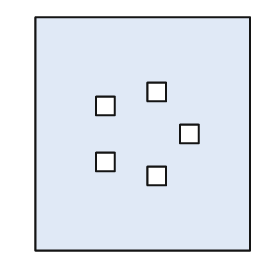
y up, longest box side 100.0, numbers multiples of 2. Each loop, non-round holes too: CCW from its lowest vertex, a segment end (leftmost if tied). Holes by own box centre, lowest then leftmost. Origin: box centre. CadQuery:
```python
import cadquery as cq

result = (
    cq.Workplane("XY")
    .moveTo(-46.0, -50.0)
    .lineTo(46.0, -50.0)
    .lineTo(46.0, 50.0)
    .lineTo(-46.0, 50.0)
    .close()
    .moveTo(2.0, -22.0)
    .lineTo(10.0, -22.0)
    .lineTo(10.0, -14.0)
    .lineTo(2.0, -14.0)
    .close()
    .moveTo(-20.0, -16.0)
    .lineTo(-12.0, -16.0)
    .lineTo(-12.0, -8.0)
    .lineTo(-20.0, -8.0)
    .close()
    .moveTo(16.0, -4.0)
    .lineTo(24.0, -4.0)
    .lineTo(24.0, 4.0)
    .lineTo(16.0, 4.0)
    .close()
    .moveTo(-20.0, 8.0)
    .lineTo(-12.0, 8.0)
    .lineTo(-12.0, 16.0)
    .lineTo(-20.0, 16.0)
    .close()
    .moveTo(2.0, 14.0)
    .lineTo(10.0, 14.0)
    .lineTo(10.0, 22.0)
    .lineTo(2.0, 22.0)
    .close()
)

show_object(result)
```